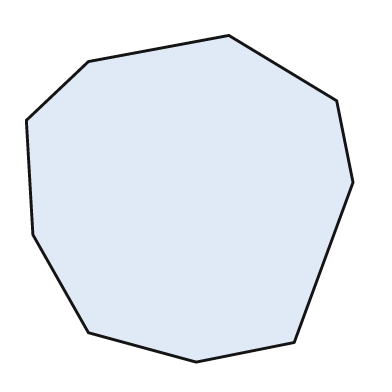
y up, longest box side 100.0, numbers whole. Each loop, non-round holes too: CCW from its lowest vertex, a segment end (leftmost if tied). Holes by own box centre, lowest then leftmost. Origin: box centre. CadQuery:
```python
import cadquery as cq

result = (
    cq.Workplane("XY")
    .moveTo(2.0, -50.0)
    .lineTo(32.0, -44.0)
    .lineTo(50.0, 5.0)
    .lineTo(45.0, 30.0)
    .lineTo(12.0, 50.0)
    .lineTo(-31.0, 42.0)
    .lineTo(-50.0, 24.0)
    .lineTo(-48.0, -11.0)
    .lineTo(-31.0, -41.0)
    .close()
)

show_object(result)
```